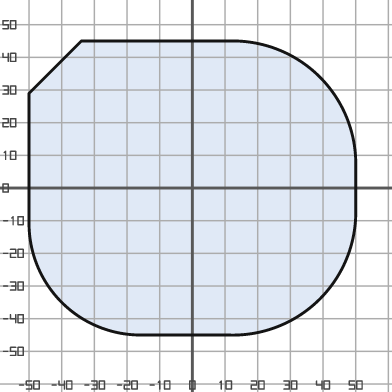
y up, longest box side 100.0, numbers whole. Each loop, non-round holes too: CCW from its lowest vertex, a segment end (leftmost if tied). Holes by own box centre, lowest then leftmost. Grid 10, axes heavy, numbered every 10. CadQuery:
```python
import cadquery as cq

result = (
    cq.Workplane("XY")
    .moveTo(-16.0, -45.0)
    .lineTo(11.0, -45.0)
    .threePointArc((39.0, -34.0), (50.0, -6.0))
    .lineTo(50.0, 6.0)
    .threePointArc((39.0, 34.0), (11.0, 45.0))
    .lineTo(-34.0, 45.0)
    .lineTo(-50.0, 29.0)
    .lineTo(-50.0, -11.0)
    .threePointArc((-40.0, -35.0), (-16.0, -45.0))
    .close()
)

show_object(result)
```